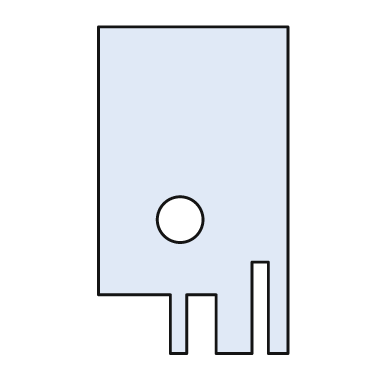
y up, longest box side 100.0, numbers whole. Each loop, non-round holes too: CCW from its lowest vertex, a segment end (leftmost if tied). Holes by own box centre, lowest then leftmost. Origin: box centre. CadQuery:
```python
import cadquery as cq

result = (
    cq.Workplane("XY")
    .moveTo(-7.0, -50.0)
    .lineTo(-2.0, -50.0)
    .lineTo(-2.0, -32.0)
    .lineTo(7.0, -32.0)
    .lineTo(7.0, -50.0)
    .lineTo(18.0, -50.0)
    .lineTo(18.0, -22.0)
    .lineTo(23.0, -22.0)
    .lineTo(23.0, -50.0)
    .lineTo(29.0, -50.0)
    .lineTo(29.0, 50.0)
    .lineTo(-29.0, 50.0)
    .lineTo(-29.0, -32.0)
    .lineTo(-7.0, -32.0)
    .close()
    .moveTo(-4.0, -9.0)
    .circle(7.0)
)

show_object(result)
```